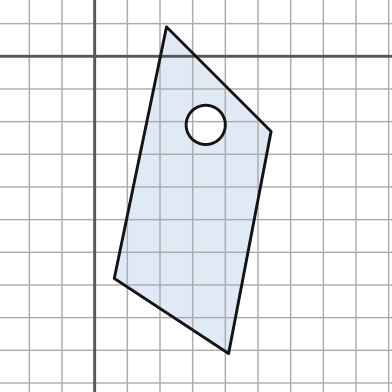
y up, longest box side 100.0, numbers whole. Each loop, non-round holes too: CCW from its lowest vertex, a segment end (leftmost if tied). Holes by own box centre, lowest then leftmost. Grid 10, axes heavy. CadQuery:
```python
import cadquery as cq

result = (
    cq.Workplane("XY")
    .moveTo(41.0, -91.0)
    .lineTo(54.0, -23.0)
    .lineTo(22.0, 9.0)
    .lineTo(6.0, -68.0)
    .close()
    .moveTo(34.0, -21.0)
    .circle(6.0)
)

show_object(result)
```